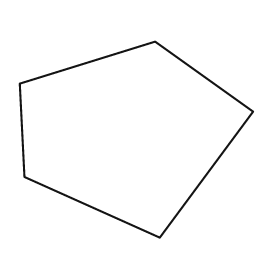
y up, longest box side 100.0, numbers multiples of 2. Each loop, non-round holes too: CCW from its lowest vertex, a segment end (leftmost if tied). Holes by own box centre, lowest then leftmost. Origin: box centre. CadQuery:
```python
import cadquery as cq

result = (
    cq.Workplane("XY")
    .moveTo(10.0, -42.0)
    .lineTo(50.0, 12.0)
    .lineTo(8.0, 42.0)
    .lineTo(-50.0, 24.0)
    .lineTo(-48.0, -16.0)
    .close()
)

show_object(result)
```